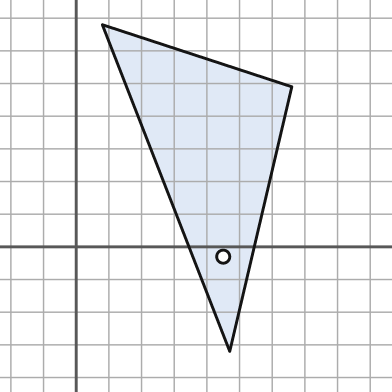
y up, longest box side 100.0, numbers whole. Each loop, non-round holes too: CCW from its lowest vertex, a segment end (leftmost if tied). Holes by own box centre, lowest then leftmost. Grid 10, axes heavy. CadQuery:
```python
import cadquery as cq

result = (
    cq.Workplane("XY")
    .moveTo(47.0, -32.0)
    .lineTo(66.0, 49.0)
    .lineTo(8.0, 68.0)
    .close()
    .moveTo(45.0, -3.0)
    .circle(2.0)
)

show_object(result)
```